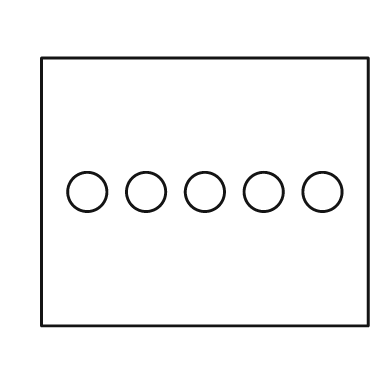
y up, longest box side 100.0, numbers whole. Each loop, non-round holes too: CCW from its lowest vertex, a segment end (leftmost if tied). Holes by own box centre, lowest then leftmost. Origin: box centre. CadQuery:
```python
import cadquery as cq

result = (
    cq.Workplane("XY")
    .moveTo(-50.0, -41.0)
    .lineTo(50.0, -41.0)
    .lineTo(50.0, 41.0)
    .lineTo(-50.0, 41.0)
    .close()
    .moveTo(-36.0, 0.0)
    .circle(6.0)
    .moveTo(-18.0, 0.0)
    .circle(6.0)
    .moveTo(0.0, 0.0)
    .circle(6.0)
    .moveTo(18.0, 0.0)
    .circle(6.0)
    .moveTo(36.0, 0.0)
    .circle(6.0)
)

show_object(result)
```